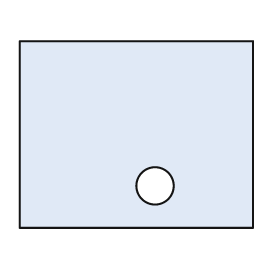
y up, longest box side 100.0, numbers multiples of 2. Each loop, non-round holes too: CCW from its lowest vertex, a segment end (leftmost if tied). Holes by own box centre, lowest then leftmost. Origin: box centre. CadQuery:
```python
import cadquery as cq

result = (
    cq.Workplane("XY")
    .moveTo(-50.0, -40.0)
    .lineTo(50.0, -40.0)
    .lineTo(50.0, 40.0)
    .lineTo(-50.0, 40.0)
    .close()
    .moveTo(8.0, -22.0)
    .circle(8.0)
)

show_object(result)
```